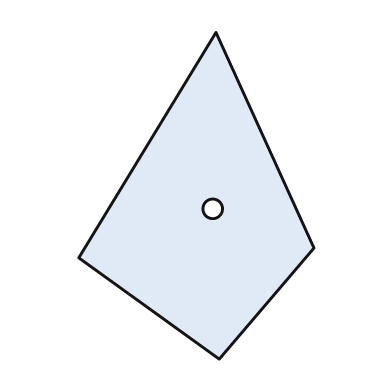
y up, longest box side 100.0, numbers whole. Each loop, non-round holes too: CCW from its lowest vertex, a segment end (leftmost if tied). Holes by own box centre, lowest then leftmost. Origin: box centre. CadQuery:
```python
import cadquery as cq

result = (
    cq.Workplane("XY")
    .moveTo(7.0, -50.0)
    .lineTo(36.0, -16.0)
    .lineTo(6.0, 50.0)
    .lineTo(-36.0, -19.0)
    .close()
    .moveTo(5.0, -4.0)
    .circle(3.0)
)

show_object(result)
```